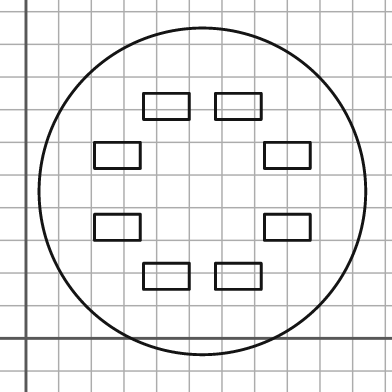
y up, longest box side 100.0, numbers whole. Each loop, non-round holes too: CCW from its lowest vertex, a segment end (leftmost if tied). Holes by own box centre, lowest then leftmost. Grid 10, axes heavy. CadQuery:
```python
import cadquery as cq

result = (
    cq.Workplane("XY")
    .moveTo(54.0, 45.0)
    .circle(50.0)
    .moveTo(36.0, 15.0)
    .lineTo(50.0, 15.0)
    .lineTo(50.0, 23.0)
    .lineTo(36.0, 23.0)
    .close()
    .moveTo(58.0, 15.0)
    .lineTo(72.0, 15.0)
    .lineTo(72.0, 23.0)
    .lineTo(58.0, 23.0)
    .close()
    .moveTo(21.0, 30.0)
    .lineTo(35.0, 30.0)
    .lineTo(35.0, 38.0)
    .lineTo(21.0, 38.0)
    .close()
    .moveTo(73.0, 30.0)
    .lineTo(87.0, 30.0)
    .lineTo(87.0, 38.0)
    .lineTo(73.0, 38.0)
    .close()
    .moveTo(21.0, 52.0)
    .lineTo(35.0, 52.0)
    .lineTo(35.0, 60.0)
    .lineTo(21.0, 60.0)
    .close()
    .moveTo(73.0, 52.0)
    .lineTo(87.0, 52.0)
    .lineTo(87.0, 60.0)
    .lineTo(73.0, 60.0)
    .close()
    .moveTo(36.0, 67.0)
    .lineTo(50.0, 67.0)
    .lineTo(50.0, 75.0)
    .lineTo(36.0, 75.0)
    .close()
    .moveTo(58.0, 67.0)
    .lineTo(72.0, 67.0)
    .lineTo(72.0, 75.0)
    .lineTo(58.0, 75.0)
    .close()
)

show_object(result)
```